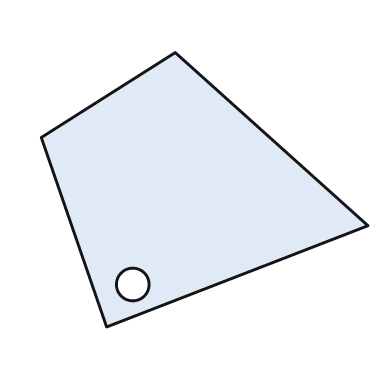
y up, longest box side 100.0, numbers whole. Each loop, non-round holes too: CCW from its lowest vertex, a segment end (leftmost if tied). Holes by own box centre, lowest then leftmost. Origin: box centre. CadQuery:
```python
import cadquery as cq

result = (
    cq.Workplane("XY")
    .moveTo(-30.0, -42.0)
    .lineTo(50.0, -11.0)
    .lineTo(-9.0, 42.0)
    .lineTo(-50.0, 16.0)
    .close()
    .moveTo(-22.0, -29.0)
    .circle(5.0)
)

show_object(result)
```